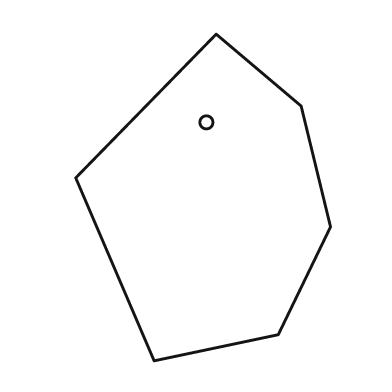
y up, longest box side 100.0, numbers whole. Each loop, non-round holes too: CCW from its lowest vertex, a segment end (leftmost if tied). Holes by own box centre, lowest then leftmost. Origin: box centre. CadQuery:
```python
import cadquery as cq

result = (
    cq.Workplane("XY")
    .moveTo(-15.0, -50.0)
    .lineTo(23.0, -42.0)
    .lineTo(39.0, -9.0)
    .lineTo(30.0, 28.0)
    .lineTo(4.0, 50.0)
    .lineTo(-39.0, 6.0)
    .close()
    .moveTo(1.0, 23.0)
    .circle(2.0)
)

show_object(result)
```